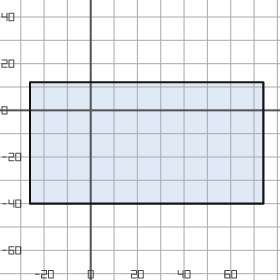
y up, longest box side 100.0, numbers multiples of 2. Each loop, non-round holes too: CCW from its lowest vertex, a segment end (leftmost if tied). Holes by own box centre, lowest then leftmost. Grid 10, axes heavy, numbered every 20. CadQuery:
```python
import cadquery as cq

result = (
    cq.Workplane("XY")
    .moveTo(-26.0, -40.0)
    .lineTo(74.0, -40.0)
    .lineTo(74.0, 12.0)
    .lineTo(-26.0, 12.0)
    .close()
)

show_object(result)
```